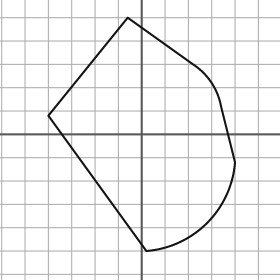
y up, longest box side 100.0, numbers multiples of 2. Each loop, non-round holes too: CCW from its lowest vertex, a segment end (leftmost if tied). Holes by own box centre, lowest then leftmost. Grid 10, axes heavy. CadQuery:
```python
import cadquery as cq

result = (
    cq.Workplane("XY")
    .moveTo(2.0, -50.0)
    .threePointArc((28.0, -38.0), (40.0, -12.0))
    .lineTo(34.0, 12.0)
    .threePointArc((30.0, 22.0), (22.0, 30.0))
    .lineTo(-6.0, 50.0)
    .lineTo(-40.0, 8.0)
    .close()
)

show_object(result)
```